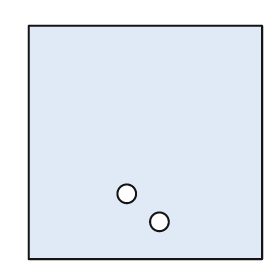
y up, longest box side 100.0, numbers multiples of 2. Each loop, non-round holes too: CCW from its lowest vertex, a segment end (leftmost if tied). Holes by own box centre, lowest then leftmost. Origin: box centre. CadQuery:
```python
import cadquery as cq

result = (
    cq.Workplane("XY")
    .moveTo(-50.0, -50.0)
    .lineTo(50.0, -50.0)
    .lineTo(50.0, 50.0)
    .lineTo(-50.0, 50.0)
    .close()
    .moveTo(6.0, -34.0)
    .circle(4.0)
    .moveTo(-8.0, -22.0)
    .circle(4.0)
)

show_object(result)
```